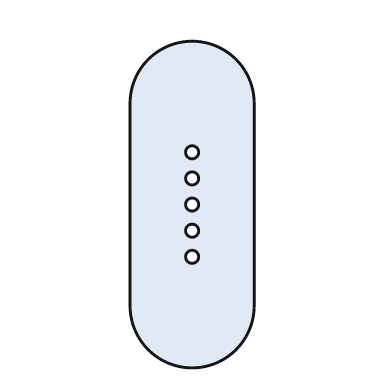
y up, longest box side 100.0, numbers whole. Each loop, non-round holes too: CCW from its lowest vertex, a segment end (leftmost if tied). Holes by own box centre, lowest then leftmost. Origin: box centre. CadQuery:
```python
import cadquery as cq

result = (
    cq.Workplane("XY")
    .moveTo(-19.0, -31.0)
    .threePointArc((0.0, -50.0), (19.0, -31.0))
    .lineTo(19.0, 31.0)
    .threePointArc((0.0, 50.0), (-19.0, 31.0))
    .close()
    .moveTo(0.0, -16.0)
    .circle(2.0)
    .moveTo(0.0, -8.0)
    .circle(2.0)
    .moveTo(0.0, 0.0)
    .circle(2.0)
    .moveTo(0.0, 8.0)
    .circle(2.0)
    .moveTo(0.0, 16.0)
    .circle(2.0)
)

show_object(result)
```